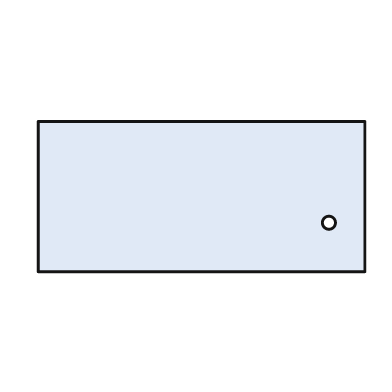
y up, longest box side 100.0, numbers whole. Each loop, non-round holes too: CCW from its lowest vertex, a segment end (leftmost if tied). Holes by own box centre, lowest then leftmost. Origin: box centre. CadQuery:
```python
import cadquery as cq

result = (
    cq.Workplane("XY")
    .moveTo(-50.0, -23.0)
    .lineTo(50.0, -23.0)
    .lineTo(50.0, 23.0)
    .lineTo(-50.0, 23.0)
    .close()
    .moveTo(39.0, -8.0)
    .circle(2.0)
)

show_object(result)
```